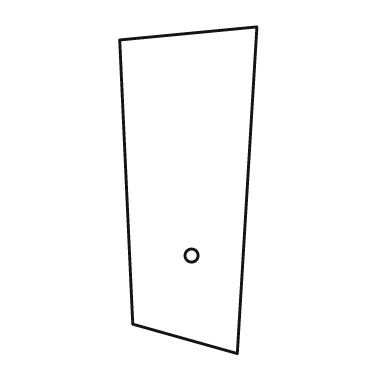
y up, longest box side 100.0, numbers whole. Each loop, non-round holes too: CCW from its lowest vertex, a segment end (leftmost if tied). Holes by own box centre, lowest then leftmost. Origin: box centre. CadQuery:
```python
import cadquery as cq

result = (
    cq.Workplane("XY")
    .moveTo(15.0, -50.0)
    .lineTo(21.0, 50.0)
    .lineTo(-21.0, 46.0)
    .lineTo(-17.0, -41.0)
    .close()
    .moveTo(1.0, -20.0)
    .circle(2.0)
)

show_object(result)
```